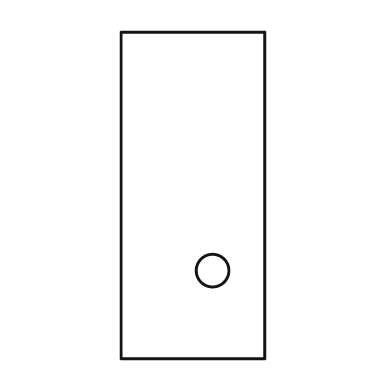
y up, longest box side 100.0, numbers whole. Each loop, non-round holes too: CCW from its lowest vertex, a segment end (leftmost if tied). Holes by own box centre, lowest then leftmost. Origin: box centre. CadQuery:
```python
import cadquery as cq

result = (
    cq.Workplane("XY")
    .moveTo(-22.0, -50.0)
    .lineTo(22.0, -50.0)
    .lineTo(22.0, 50.0)
    .lineTo(-22.0, 50.0)
    .close()
    .moveTo(6.0, -23.0)
    .circle(5.0)
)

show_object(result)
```